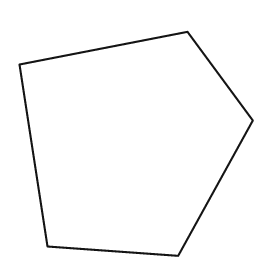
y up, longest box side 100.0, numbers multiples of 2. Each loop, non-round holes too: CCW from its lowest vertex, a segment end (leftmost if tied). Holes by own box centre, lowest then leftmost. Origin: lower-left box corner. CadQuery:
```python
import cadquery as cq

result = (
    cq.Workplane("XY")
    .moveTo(68.0, 0.0)
    .lineTo(100.0, 58.0)
    .lineTo(72.0, 96.0)
    .lineTo(0.0, 82.0)
    .lineTo(12.0, 4.0)
    .close()
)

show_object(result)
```